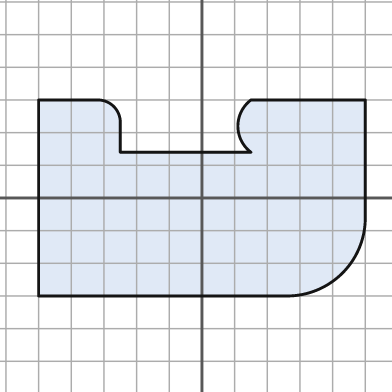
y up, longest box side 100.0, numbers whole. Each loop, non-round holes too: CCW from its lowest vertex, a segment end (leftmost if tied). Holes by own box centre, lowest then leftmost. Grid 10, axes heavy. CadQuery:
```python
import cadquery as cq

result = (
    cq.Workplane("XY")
    .moveTo(-50.0, -30.0)
    .lineTo(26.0, -30.0)
    .threePointArc((43.0, -23.0), (50.0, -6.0))
    .lineTo(50.0, 30.0)
    .lineTo(15.0, 30.0)
    .threePointArc((11.0, 22.0), (15.0, 14.0))
    .lineTo(-25.0, 14.0)
    .lineTo(-25.0, 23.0)
    .threePointArc((-27.0, 28.0), (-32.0, 30.0))
    .lineTo(-50.0, 30.0)
    .close()
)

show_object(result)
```